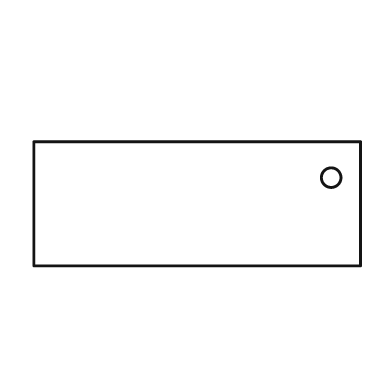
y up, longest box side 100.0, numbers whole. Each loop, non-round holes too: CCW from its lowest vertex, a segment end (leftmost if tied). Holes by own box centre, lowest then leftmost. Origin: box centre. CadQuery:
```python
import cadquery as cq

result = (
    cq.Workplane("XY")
    .moveTo(-50.0, -19.0)
    .lineTo(50.0, -19.0)
    .lineTo(50.0, 19.0)
    .lineTo(-50.0, 19.0)
    .close()
    .moveTo(41.0, 8.0)
    .circle(3.0)
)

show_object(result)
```